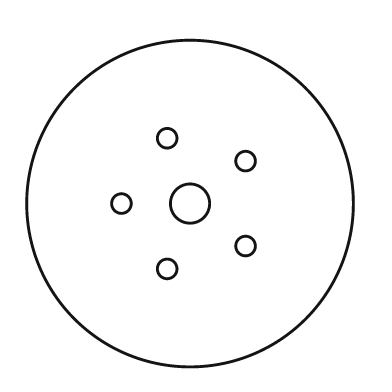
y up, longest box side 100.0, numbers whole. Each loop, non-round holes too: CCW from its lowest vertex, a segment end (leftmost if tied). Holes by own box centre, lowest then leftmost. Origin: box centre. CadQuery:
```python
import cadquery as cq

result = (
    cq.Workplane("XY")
    .moveTo(0.0, 0.0)
    .circle(50.0)
    .moveTo(-7.0, -20.0)
    .circle(3.0)
    .moveTo(17.0, -13.0)
    .circle(3.0)
    .moveTo(-21.0, 0.0)
    .circle(3.0)
    .moveTo(0.0, 0.0)
    .circle(6.0)
    .moveTo(17.0, 13.0)
    .circle(3.0)
    .moveTo(-7.0, 20.0)
    .circle(3.0)
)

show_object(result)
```